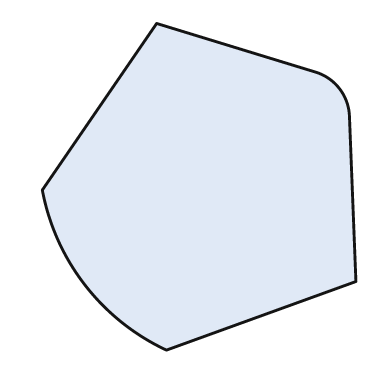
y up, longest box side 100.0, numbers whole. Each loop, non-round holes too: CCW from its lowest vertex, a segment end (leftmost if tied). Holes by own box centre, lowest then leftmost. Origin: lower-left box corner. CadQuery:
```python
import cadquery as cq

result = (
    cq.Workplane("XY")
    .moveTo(38.0, 0.0)
    .lineTo(96.0, 21.0)
    .lineTo(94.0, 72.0)
    .threePointArc((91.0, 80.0), (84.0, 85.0))
    .lineTo(35.0, 100.0)
    .lineTo(0.0, 49.0)
    .threePointArc((13.0, 20.0), (38.0, 0.0))
    .close()
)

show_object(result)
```